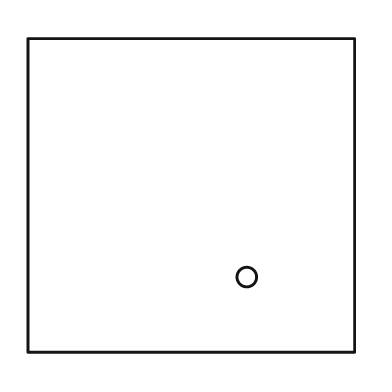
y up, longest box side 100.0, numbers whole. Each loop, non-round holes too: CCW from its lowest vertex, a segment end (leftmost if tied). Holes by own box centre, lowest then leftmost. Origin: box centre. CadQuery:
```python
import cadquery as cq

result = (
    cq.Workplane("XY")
    .moveTo(-50.0, -48.0)
    .lineTo(50.0, -48.0)
    .lineTo(50.0, 48.0)
    .lineTo(-50.0, 48.0)
    .close()
    .moveTo(17.0, -25.0)
    .circle(3.0)
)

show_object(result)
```